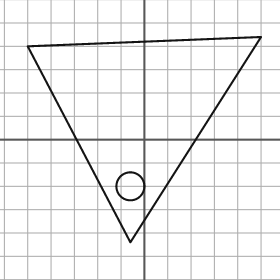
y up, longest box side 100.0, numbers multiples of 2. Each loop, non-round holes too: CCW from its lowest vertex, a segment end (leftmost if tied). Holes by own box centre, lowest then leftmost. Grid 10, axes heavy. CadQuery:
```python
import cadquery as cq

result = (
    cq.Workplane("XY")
    .moveTo(-6.0, -44.0)
    .lineTo(50.0, 44.0)
    .lineTo(-50.0, 40.0)
    .close()
    .moveTo(-6.0, -20.0)
    .circle(6.0)
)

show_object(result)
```